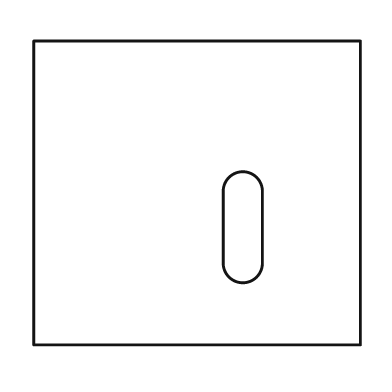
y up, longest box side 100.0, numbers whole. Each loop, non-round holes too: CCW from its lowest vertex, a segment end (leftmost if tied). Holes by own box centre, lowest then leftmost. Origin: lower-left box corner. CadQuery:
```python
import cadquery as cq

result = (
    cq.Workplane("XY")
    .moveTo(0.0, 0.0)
    .lineTo(100.0, 0.0)
    .lineTo(100.0, 93.0)
    .lineTo(0.0, 93.0)
    .close()
    .moveTo(58.0, 25.0)
    .threePointArc((64.0, 19.0), (70.0, 25.0))
    .lineTo(70.0, 47.0)
    .threePointArc((64.0, 53.0), (58.0, 47.0))
    .close()
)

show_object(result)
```